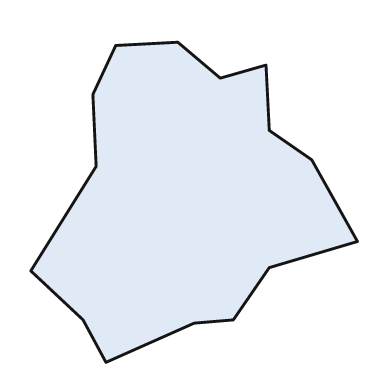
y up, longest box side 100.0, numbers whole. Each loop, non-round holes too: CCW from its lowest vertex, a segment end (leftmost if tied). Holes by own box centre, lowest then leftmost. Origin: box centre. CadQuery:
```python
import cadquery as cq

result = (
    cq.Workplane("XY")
    .moveTo(-27.0, -49.0)
    .lineTo(0.0, -37.0)
    .lineTo(12.0, -36.0)
    .lineTo(23.0, -20.0)
    .lineTo(50.0, -12.0)
    .lineTo(36.0, 13.0)
    .lineTo(23.0, 22.0)
    .lineTo(22.0, 42.0)
    .lineTo(8.0, 38.0)
    .lineTo(-5.0, 49.0)
    .lineTo(-24.0, 48.0)
    .lineTo(-31.0, 33.0)
    .lineTo(-30.0, 11.0)
    .lineTo(-50.0, -21.0)
    .lineTo(-34.0, -36.0)
    .close()
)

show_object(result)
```